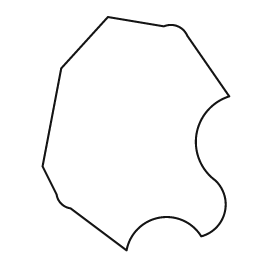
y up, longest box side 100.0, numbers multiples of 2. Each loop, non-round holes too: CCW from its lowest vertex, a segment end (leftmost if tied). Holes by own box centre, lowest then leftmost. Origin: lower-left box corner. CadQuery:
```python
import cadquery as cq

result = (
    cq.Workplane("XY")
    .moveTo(36.0, 0.0)
    .threePointArc((50.0, 14.0), (68.0, 6.0))
    .threePointArc((78.0, 16.0), (74.0, 30.0))
    .threePointArc((66.0, 50.0), (80.0, 66.0))
    .lineTo(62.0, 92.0)
    .threePointArc((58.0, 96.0), (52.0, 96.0))
    .lineTo(28.0, 100.0)
    .lineTo(8.0, 78.0)
    .lineTo(0.0, 36.0)
    .lineTo(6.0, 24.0)
    .threePointArc((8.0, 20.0), (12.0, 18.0))
    .close()
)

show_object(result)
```